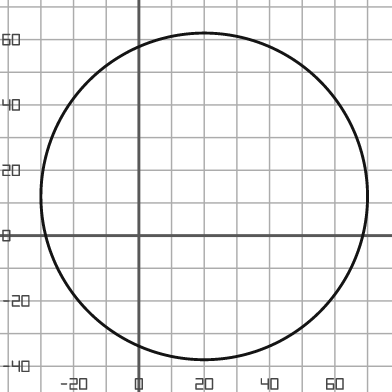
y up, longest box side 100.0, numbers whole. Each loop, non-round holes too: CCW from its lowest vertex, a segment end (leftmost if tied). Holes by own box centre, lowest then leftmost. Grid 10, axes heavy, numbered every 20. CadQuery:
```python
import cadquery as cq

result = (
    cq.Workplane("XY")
    .moveTo(20.0, 12.0)
    .circle(50.0)
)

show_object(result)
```